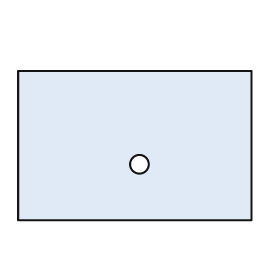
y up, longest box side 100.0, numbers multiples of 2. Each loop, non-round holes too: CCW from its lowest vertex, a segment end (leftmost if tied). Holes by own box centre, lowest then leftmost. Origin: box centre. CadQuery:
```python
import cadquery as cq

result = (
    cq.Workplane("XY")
    .moveTo(-50.0, -32.0)
    .lineTo(50.0, -32.0)
    .lineTo(50.0, 32.0)
    .lineTo(-50.0, 32.0)
    .close()
    .moveTo(2.0, -8.0)
    .circle(4.0)
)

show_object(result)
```